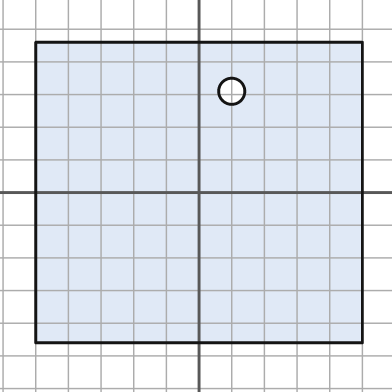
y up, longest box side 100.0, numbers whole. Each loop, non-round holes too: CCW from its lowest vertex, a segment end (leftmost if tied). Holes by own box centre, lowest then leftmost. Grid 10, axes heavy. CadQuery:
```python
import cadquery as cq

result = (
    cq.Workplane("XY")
    .moveTo(-50.0, -46.0)
    .lineTo(50.0, -46.0)
    .lineTo(50.0, 46.0)
    .lineTo(-50.0, 46.0)
    .close()
    .moveTo(10.0, 31.0)
    .circle(4.0)
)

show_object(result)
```